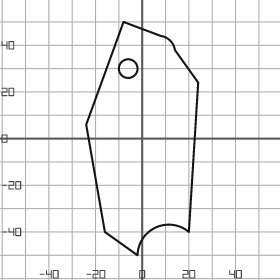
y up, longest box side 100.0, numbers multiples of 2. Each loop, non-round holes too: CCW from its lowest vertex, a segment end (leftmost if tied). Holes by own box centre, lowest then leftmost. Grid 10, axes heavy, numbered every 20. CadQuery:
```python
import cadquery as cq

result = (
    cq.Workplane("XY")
    .moveTo(-2.0, -50.0)
    .threePointArc((6.0, -38.0), (20.0, -40.0))
    .lineTo(24.0, 24.0)
    .lineTo(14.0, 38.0)
    .threePointArc((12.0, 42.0), (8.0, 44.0))
    .lineTo(-8.0, 50.0)
    .lineTo(-24.0, 6.0)
    .lineTo(-16.0, -40.0)
    .close()
    .moveTo(-6.0, 30.0)
    .circle(4.0)
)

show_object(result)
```